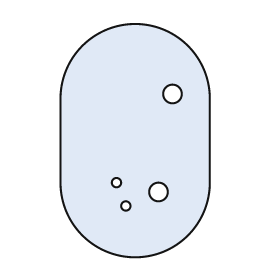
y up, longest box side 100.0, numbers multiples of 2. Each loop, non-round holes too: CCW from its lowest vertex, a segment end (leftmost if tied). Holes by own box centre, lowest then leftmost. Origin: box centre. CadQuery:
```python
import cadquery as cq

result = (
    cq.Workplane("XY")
    .moveTo(-32.0, -18.0)
    .threePointArc((0.0, -50.0), (32.0, -18.0))
    .lineTo(32.0, 18.0)
    .threePointArc((0.0, 50.0), (-32.0, 18.0))
    .close()
    .moveTo(-4.0, -28.0)
    .circle(2.0)
    .moveTo(10.0, -22.0)
    .circle(4.0)
    .moveTo(-8.0, -18.0)
    .circle(2.0)
    .moveTo(16.0, 20.0)
    .circle(4.0)
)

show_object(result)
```